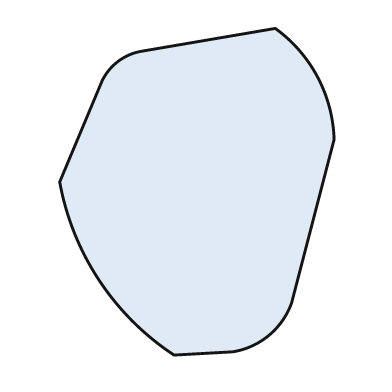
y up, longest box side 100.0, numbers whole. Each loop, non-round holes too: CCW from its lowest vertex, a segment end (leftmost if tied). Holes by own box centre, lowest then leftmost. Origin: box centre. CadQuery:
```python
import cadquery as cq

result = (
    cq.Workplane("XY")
    .moveTo(-7.0, -50.0)
    .lineTo(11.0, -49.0)
    .threePointArc((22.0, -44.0), (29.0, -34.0))
    .lineTo(42.0, 16.0)
    .threePointArc((37.0, 35.0), (24.0, 50.0))
    .lineTo(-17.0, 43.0)
    .threePointArc((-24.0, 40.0), (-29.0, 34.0))
    .lineTo(-42.0, 3.0)
    .threePointArc((-30.0, -27.0), (-7.0, -50.0))
    .close()
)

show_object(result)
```